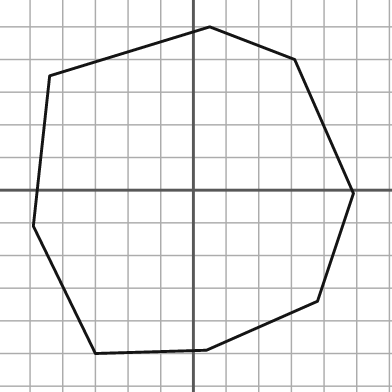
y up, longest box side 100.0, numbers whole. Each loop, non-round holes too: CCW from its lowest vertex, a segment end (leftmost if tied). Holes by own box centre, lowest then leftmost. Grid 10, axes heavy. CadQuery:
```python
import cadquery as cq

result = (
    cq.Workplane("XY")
    .moveTo(-30.0, -50.0)
    .lineTo(4.0, -49.0)
    .lineTo(38.0, -34.0)
    .lineTo(49.0, -1.0)
    .lineTo(31.0, 40.0)
    .lineTo(5.0, 50.0)
    .lineTo(-44.0, 35.0)
    .lineTo(-49.0, -11.0)
    .close()
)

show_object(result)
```